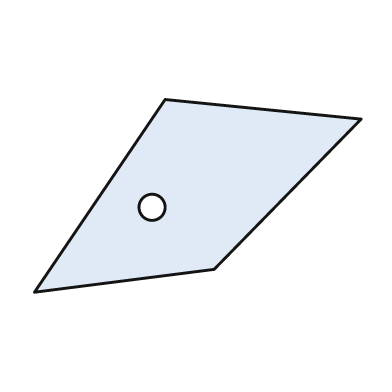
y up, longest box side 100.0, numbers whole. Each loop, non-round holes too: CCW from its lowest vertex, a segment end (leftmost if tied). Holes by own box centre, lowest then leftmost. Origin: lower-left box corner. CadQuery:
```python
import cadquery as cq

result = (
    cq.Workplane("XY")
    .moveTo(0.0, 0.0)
    .lineTo(55.0, 7.0)
    .lineTo(100.0, 53.0)
    .lineTo(40.0, 59.0)
    .close()
    .moveTo(36.0, 26.0)
    .circle(4.0)
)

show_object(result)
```